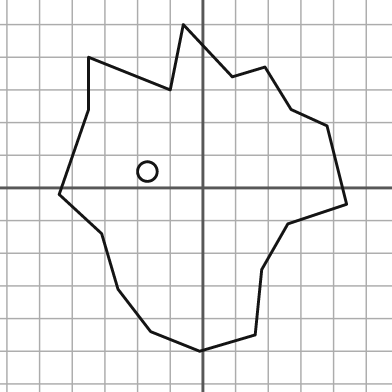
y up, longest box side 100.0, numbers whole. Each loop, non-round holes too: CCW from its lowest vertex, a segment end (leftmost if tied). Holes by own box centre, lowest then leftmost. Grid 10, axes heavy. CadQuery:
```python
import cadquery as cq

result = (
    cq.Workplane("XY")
    .moveTo(-1.0, -50.0)
    .lineTo(16.0, -45.0)
    .lineTo(18.0, -25.0)
    .lineTo(26.0, -11.0)
    .lineTo(44.0, -5.0)
    .lineTo(38.0, 19.0)
    .lineTo(27.0, 24.0)
    .lineTo(19.0, 37.0)
    .lineTo(9.0, 34.0)
    .lineTo(-6.0, 50.0)
    .lineTo(-10.0, 30.0)
    .lineTo(-35.0, 40.0)
    .lineTo(-35.0, 24.0)
    .lineTo(-44.0, -2.0)
    .lineTo(-31.0, -14.0)
    .lineTo(-26.0, -31.0)
    .lineTo(-16.0, -44.0)
    .close()
    .moveTo(-17.0, 5.0)
    .circle(3.0)
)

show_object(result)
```